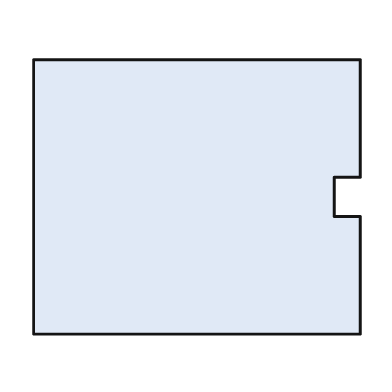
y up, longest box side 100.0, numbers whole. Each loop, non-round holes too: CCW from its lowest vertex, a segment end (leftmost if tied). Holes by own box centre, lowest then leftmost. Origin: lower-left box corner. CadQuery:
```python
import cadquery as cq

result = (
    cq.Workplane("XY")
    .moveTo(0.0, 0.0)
    .lineTo(100.0, 0.0)
    .lineTo(100.0, 36.0)
    .lineTo(92.0, 36.0)
    .lineTo(92.0, 48.0)
    .lineTo(100.0, 48.0)
    .lineTo(100.0, 84.0)
    .lineTo(0.0, 84.0)
    .close()
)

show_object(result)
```